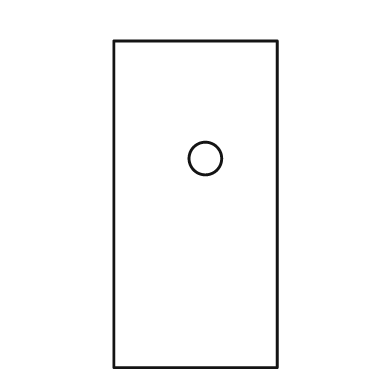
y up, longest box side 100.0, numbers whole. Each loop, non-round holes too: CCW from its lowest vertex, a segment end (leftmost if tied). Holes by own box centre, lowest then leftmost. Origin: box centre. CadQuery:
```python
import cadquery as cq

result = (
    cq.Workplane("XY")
    .moveTo(-25.0, -50.0)
    .lineTo(25.0, -50.0)
    .lineTo(25.0, 50.0)
    .lineTo(-25.0, 50.0)
    .close()
    .moveTo(3.0, 14.0)
    .circle(5.0)
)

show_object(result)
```